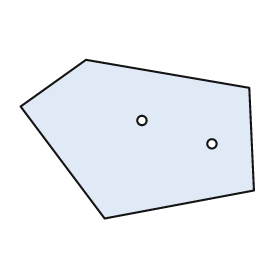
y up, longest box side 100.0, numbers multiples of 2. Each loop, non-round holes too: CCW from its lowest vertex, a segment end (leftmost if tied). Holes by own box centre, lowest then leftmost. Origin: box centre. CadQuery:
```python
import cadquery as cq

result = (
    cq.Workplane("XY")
    .moveTo(-14.0, -34.0)
    .lineTo(50.0, -22.0)
    .lineTo(48.0, 22.0)
    .lineTo(-22.0, 34.0)
    .lineTo(-50.0, 14.0)
    .close()
    .moveTo(32.0, -2.0)
    .circle(2.0)
    .moveTo(2.0, 8.0)
    .circle(2.0)
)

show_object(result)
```